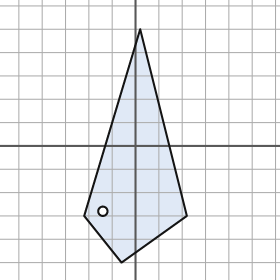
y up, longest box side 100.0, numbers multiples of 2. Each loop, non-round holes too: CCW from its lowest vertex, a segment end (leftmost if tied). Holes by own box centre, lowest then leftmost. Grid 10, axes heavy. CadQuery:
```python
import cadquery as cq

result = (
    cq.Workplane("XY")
    .moveTo(-6.0, -50.0)
    .lineTo(22.0, -30.0)
    .lineTo(2.0, 50.0)
    .lineTo(-22.0, -30.0)
    .close()
    .moveTo(-14.0, -28.0)
    .circle(2.0)
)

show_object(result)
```